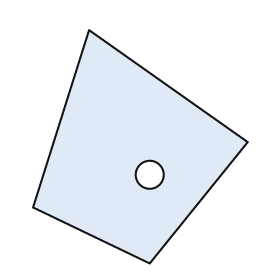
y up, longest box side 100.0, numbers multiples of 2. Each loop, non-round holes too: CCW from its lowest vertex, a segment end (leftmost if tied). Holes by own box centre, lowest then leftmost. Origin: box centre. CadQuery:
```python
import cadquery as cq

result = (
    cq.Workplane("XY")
    .moveTo(4.0, -50.0)
    .lineTo(46.0, 2.0)
    .lineTo(-22.0, 50.0)
    .lineTo(-46.0, -26.0)
    .close()
    .moveTo(4.0, -12.0)
    .circle(6.0)
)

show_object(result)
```